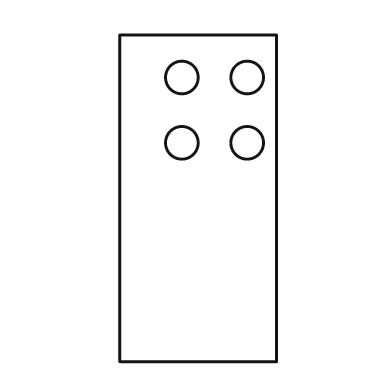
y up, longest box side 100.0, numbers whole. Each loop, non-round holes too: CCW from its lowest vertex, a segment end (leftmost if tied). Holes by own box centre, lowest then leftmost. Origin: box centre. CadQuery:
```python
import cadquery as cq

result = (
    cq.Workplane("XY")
    .moveTo(-24.0, -50.0)
    .lineTo(24.0, -50.0)
    .lineTo(24.0, 50.0)
    .lineTo(-24.0, 50.0)
    .close()
    .moveTo(-5.0, 17.0)
    .circle(5.0)
    .moveTo(15.0, 17.0)
    .circle(5.0)
    .moveTo(-5.0, 37.0)
    .circle(5.0)
    .moveTo(15.0, 37.0)
    .circle(5.0)
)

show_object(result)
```